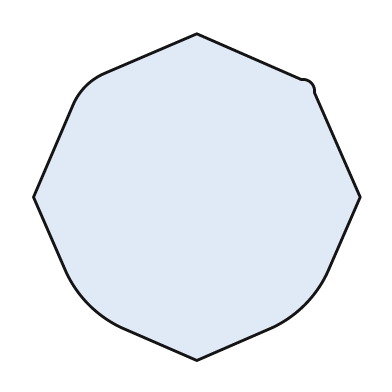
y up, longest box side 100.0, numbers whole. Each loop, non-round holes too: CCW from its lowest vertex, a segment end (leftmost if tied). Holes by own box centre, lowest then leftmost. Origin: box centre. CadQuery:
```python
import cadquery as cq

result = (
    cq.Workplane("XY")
    .moveTo(0.0, -50.0)
    .lineTo(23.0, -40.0)
    .threePointArc((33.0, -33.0), (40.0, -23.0))
    .lineTo(50.0, 0.0)
    .lineTo(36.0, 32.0)
    .threePointArc((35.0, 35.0), (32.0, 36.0))
    .lineTo(0.0, 50.0)
    .lineTo(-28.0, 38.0)
    .threePointArc((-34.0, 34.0), (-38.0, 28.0))
    .lineTo(-50.0, 0.0)
    .lineTo(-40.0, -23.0)
    .threePointArc((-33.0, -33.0), (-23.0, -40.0))
    .close()
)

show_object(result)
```